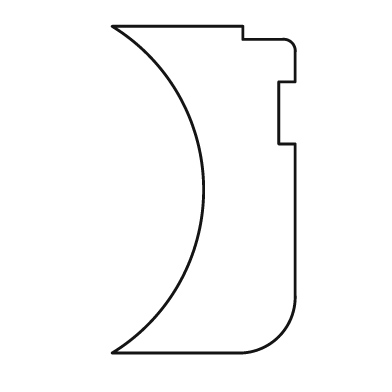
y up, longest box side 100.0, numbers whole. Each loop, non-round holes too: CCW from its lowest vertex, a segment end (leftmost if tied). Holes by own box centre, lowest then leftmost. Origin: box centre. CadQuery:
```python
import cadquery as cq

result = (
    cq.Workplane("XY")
    .moveTo(-28.0, -50.0)
    .lineTo(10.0, -50.0)
    .threePointArc((23.0, -45.0), (28.0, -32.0))
    .lineTo(28.0, 14.0)
    .lineTo(23.0, 14.0)
    .lineTo(23.0, 33.0)
    .lineTo(28.0, 33.0)
    .lineTo(28.0, 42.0)
    .threePointArc((27.0, 45.0), (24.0, 46.0))
    .lineTo(12.0, 46.0)
    .lineTo(12.0, 50.0)
    .lineTo(-28.0, 50.0)
    .threePointArc((0.0, 0.0), (-28.0, -50.0))
    .close()
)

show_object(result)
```